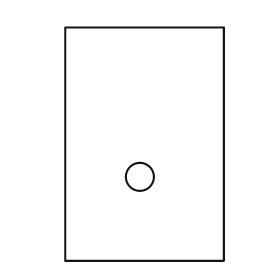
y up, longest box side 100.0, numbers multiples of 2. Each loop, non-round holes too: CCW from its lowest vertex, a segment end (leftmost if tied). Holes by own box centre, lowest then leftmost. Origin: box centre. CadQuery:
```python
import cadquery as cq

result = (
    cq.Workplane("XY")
    .moveTo(-34.0, -50.0)
    .lineTo(34.0, -50.0)
    .lineTo(34.0, 50.0)
    .lineTo(-34.0, 50.0)
    .close()
    .moveTo(-2.0, -14.0)
    .circle(6.0)
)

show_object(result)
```